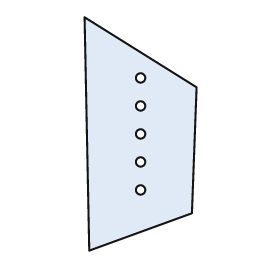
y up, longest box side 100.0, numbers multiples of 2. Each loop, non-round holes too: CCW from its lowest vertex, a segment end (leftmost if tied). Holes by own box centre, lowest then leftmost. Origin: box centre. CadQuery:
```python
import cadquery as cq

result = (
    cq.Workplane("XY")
    .moveTo(-22.0, -50.0)
    .lineTo(22.0, -34.0)
    .lineTo(24.0, 20.0)
    .lineTo(-24.0, 50.0)
    .close()
    .moveTo(0.0, -24.0)
    .circle(2.0)
    .moveTo(0.0, -12.0)
    .circle(2.0)
    .moveTo(0.0, 0.0)
    .circle(2.0)
    .moveTo(0.0, 12.0)
    .circle(2.0)
    .moveTo(0.0, 24.0)
    .circle(2.0)
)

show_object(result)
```